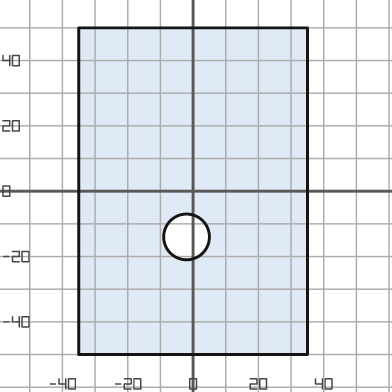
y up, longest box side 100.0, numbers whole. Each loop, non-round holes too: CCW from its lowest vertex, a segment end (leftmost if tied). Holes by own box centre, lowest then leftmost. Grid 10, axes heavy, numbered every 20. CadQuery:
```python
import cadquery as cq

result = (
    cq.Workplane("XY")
    .moveTo(-35.0, -50.0)
    .lineTo(35.0, -50.0)
    .lineTo(35.0, 50.0)
    .lineTo(-35.0, 50.0)
    .close()
    .moveTo(-2.0, -14.0)
    .circle(7.0)
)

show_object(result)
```